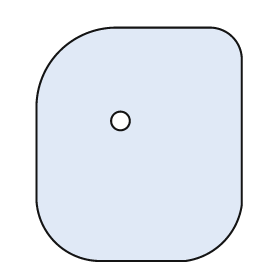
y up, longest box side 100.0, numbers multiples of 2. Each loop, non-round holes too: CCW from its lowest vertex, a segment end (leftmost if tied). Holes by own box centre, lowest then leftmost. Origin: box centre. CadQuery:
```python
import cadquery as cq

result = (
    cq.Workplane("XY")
    .moveTo(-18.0, -50.0)
    .lineTo(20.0, -50.0)
    .threePointArc((36.0, -42.0), (44.0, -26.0))
    .lineTo(44.0, 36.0)
    .threePointArc((40.0, 46.0), (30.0, 50.0))
    .lineTo(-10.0, 50.0)
    .threePointArc((-34.0, 40.0), (-44.0, 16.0))
    .lineTo(-44.0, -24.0)
    .threePointArc((-36.0, -42.0), (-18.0, -50.0))
    .close()
    .moveTo(-8.0, 10.0)
    .circle(4.0)
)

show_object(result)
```